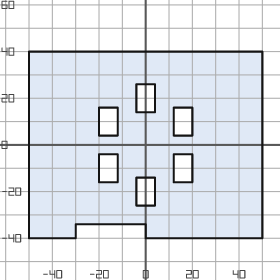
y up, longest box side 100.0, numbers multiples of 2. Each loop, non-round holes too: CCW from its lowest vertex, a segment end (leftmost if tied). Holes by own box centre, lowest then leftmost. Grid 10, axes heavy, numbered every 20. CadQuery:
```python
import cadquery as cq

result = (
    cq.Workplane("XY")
    .moveTo(-50.0, -40.0)
    .lineTo(-30.0, -40.0)
    .lineTo(-30.0, -34.0)
    .lineTo(0.0, -34.0)
    .lineTo(0.0, -40.0)
    .lineTo(50.0, -40.0)
    .lineTo(50.0, 40.0)
    .lineTo(-50.0, 40.0)
    .close()
    .moveTo(-4.0, -26.0)
    .lineTo(4.0, -26.0)
    .lineTo(4.0, -14.0)
    .lineTo(-4.0, -14.0)
    .close()
    .moveTo(-20.0, -16.0)
    .lineTo(-12.0, -16.0)
    .lineTo(-12.0, -4.0)
    .lineTo(-20.0, -4.0)
    .close()
    .moveTo(12.0, -16.0)
    .lineTo(20.0, -16.0)
    .lineTo(20.0, -4.0)
    .lineTo(12.0, -4.0)
    .close()
    .moveTo(-20.0, 4.0)
    .lineTo(-12.0, 4.0)
    .lineTo(-12.0, 16.0)
    .lineTo(-20.0, 16.0)
    .close()
    .moveTo(12.0, 4.0)
    .lineTo(20.0, 4.0)
    .lineTo(20.0, 16.0)
    .lineTo(12.0, 16.0)
    .close()
    .moveTo(-4.0, 14.0)
    .lineTo(4.0, 14.0)
    .lineTo(4.0, 26.0)
    .lineTo(-4.0, 26.0)
    .close()
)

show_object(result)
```